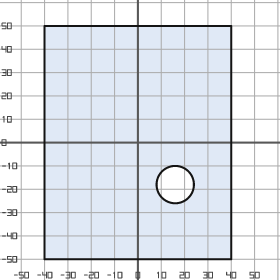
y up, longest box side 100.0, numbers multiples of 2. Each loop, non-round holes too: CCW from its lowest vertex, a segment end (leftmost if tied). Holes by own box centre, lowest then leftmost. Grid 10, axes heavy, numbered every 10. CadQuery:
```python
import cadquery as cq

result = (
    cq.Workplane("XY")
    .moveTo(-40.0, -50.0)
    .lineTo(40.0, -50.0)
    .lineTo(40.0, 50.0)
    .lineTo(-40.0, 50.0)
    .close()
    .moveTo(16.0, -18.0)
    .circle(8.0)
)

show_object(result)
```